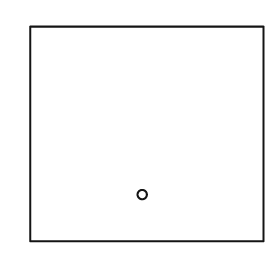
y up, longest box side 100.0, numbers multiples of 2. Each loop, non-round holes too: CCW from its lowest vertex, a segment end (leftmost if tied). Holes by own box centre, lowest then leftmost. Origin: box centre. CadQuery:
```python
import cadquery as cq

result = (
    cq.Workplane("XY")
    .moveTo(-50.0, -46.0)
    .lineTo(50.0, -46.0)
    .lineTo(50.0, 46.0)
    .lineTo(-50.0, 46.0)
    .close()
    .moveTo(-2.0, -26.0)
    .circle(2.0)
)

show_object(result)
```